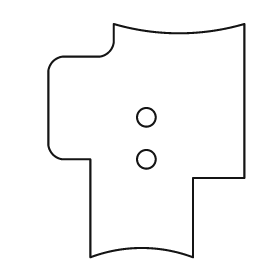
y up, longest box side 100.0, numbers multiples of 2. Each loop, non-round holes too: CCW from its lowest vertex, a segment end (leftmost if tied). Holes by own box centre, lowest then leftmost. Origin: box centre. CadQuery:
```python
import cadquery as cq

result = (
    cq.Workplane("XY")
    .moveTo(-24.0, -50.0)
    .threePointArc((-2.0, -46.0), (20.0, -50.0))
    .lineTo(20.0, -16.0)
    .lineTo(42.0, -16.0)
    .lineTo(42.0, 50.0)
    .threePointArc((14.0, 46.0), (-14.0, 50.0))
    .lineTo(-14.0, 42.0)
    .threePointArc((-16.0, 38.0), (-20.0, 36.0))
    .lineTo(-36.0, 36.0)
    .threePointArc((-40.0, 34.0), (-42.0, 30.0))
    .lineTo(-42.0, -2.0)
    .threePointArc((-40.0, -6.0), (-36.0, -8.0))
    .lineTo(-24.0, -8.0)
    .close()
    .moveTo(0.0, -8.0)
    .circle(4.0)
    .moveTo(0.0, 10.0)
    .circle(4.0)
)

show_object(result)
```